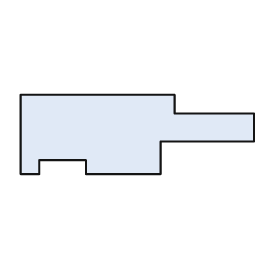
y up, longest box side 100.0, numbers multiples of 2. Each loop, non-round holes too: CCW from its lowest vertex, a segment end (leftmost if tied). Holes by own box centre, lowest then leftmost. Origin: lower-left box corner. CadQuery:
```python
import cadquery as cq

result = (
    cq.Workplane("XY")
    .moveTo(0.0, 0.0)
    .lineTo(8.0, 0.0)
    .lineTo(8.0, 6.0)
    .lineTo(28.0, 6.0)
    .lineTo(28.0, 0.0)
    .lineTo(60.0, 0.0)
    .lineTo(60.0, 14.0)
    .lineTo(100.0, 14.0)
    .lineTo(100.0, 26.0)
    .lineTo(66.0, 26.0)
    .lineTo(66.0, 34.0)
    .lineTo(0.0, 34.0)
    .close()
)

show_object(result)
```